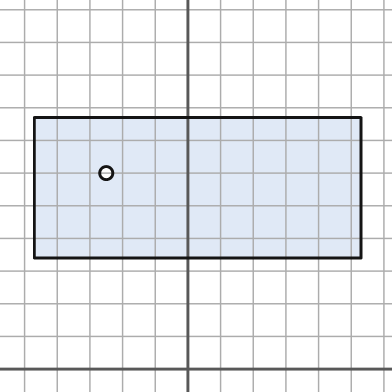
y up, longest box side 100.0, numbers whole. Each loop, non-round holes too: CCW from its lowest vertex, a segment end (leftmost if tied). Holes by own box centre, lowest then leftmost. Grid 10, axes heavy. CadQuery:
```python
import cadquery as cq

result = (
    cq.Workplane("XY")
    .moveTo(-47.0, 34.0)
    .lineTo(53.0, 34.0)
    .lineTo(53.0, 77.0)
    .lineTo(-47.0, 77.0)
    .close()
    .moveTo(-25.0, 60.0)
    .circle(2.0)
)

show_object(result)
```